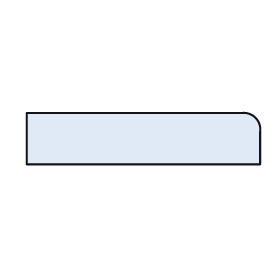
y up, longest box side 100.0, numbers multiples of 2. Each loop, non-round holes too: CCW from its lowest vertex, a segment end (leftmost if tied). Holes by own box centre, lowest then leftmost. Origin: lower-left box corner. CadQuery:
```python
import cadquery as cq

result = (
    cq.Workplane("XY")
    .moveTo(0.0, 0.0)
    .lineTo(100.0, 0.0)
    .lineTo(100.0, 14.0)
    .threePointArc((98.0, 20.0), (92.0, 22.0))
    .lineTo(0.0, 22.0)
    .close()
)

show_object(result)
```